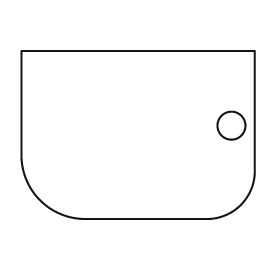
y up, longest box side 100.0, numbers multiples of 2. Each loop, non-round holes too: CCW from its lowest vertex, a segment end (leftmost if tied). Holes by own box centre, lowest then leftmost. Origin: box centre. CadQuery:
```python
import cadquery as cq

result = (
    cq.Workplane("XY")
    .moveTo(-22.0, -36.0)
    .lineTo(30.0, -36.0)
    .threePointArc((44.0, -30.0), (50.0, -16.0))
    .lineTo(50.0, 36.0)
    .lineTo(-50.0, 36.0)
    .lineTo(-50.0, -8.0)
    .threePointArc((-42.0, -28.0), (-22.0, -36.0))
    .close()
    .moveTo(40.0, 4.0)
    .circle(6.0)
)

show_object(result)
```